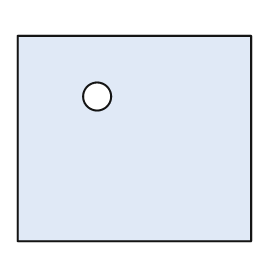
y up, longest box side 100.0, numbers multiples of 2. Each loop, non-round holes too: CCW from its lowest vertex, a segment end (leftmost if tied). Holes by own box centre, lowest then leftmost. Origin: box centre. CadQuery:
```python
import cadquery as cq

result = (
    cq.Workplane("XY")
    .moveTo(-50.0, -44.0)
    .lineTo(50.0, -44.0)
    .lineTo(50.0, 44.0)
    .lineTo(-50.0, 44.0)
    .close()
    .moveTo(-16.0, 18.0)
    .circle(6.0)
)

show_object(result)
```